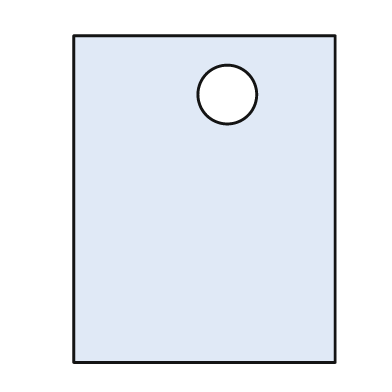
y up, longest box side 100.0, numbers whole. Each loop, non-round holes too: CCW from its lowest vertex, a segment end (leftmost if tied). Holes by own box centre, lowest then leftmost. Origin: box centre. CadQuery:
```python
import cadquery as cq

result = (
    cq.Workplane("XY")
    .moveTo(-40.0, -50.0)
    .lineTo(40.0, -50.0)
    .lineTo(40.0, 50.0)
    .lineTo(-40.0, 50.0)
    .close()
    .moveTo(7.0, 32.0)
    .circle(9.0)
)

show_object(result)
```